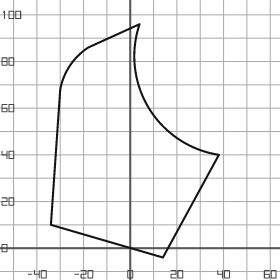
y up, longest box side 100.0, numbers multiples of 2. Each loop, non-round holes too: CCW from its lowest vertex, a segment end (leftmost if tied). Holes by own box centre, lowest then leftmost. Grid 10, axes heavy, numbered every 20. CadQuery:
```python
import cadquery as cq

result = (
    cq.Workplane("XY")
    .moveTo(14.0, -4.0)
    .lineTo(38.0, 40.0)
    .threePointArc((8.0, 60.0), (4.0, 96.0))
    .lineTo(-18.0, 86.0)
    .threePointArc((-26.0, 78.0), (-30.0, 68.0))
    .lineTo(-34.0, 10.0)
    .close()
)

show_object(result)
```